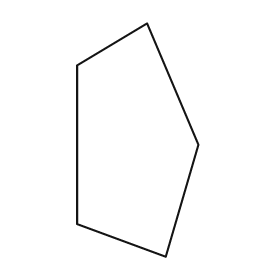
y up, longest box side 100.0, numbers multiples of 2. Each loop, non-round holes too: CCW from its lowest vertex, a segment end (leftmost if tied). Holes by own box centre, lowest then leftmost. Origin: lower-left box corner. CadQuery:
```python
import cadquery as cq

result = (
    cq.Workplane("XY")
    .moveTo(38.0, 0.0)
    .lineTo(52.0, 48.0)
    .lineTo(30.0, 100.0)
    .lineTo(0.0, 82.0)
    .lineTo(0.0, 14.0)
    .close()
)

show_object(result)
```